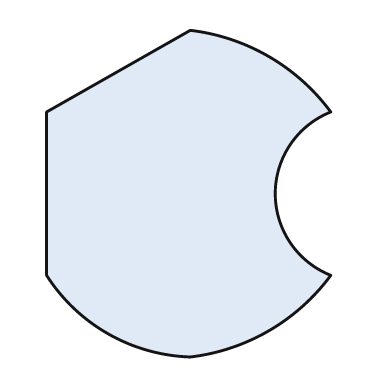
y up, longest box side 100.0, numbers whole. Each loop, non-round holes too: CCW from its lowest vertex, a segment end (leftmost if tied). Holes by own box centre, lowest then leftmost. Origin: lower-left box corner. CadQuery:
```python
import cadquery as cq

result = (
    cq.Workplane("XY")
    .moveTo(44.0, 0.0)
    .threePointArc((68.0, 8.0), (87.0, 25.0))
    .threePointArc((70.0, 50.0), (87.0, 75.0))
    .threePointArc((68.0, 92.0), (44.0, 100.0))
    .lineTo(0.0, 75.0)
    .lineTo(0.0, 25.0)
    .threePointArc((19.0, 7.0), (44.0, 0.0))
    .close()
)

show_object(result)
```